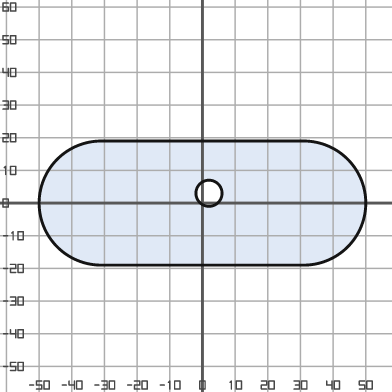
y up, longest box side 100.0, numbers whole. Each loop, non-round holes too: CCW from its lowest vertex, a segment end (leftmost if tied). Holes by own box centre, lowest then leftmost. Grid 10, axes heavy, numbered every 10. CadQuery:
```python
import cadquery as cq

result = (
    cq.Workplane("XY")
    .moveTo(-31.0, -19.0)
    .lineTo(31.0, -19.0)
    .threePointArc((50.0, 0.0), (31.0, 19.0))
    .lineTo(-31.0, 19.0)
    .threePointArc((-50.0, 0.0), (-31.0, -19.0))
    .close()
    .moveTo(2.0, 3.0)
    .circle(4.0)
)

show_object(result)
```